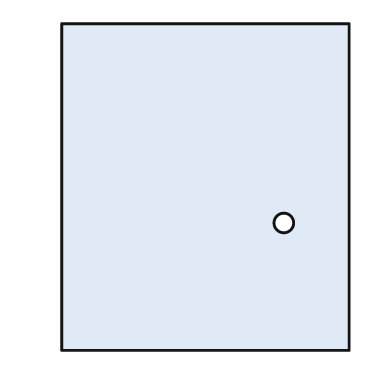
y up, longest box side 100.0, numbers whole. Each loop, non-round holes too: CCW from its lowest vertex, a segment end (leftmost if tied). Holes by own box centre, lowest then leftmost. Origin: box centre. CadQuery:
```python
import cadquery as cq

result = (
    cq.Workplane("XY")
    .moveTo(-44.0, -50.0)
    .lineTo(44.0, -50.0)
    .lineTo(44.0, 50.0)
    .lineTo(-44.0, 50.0)
    .close()
    .moveTo(24.0, -11.0)
    .circle(3.0)
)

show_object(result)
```